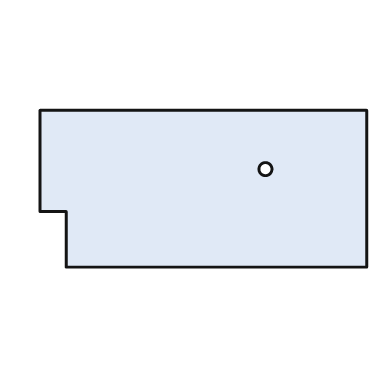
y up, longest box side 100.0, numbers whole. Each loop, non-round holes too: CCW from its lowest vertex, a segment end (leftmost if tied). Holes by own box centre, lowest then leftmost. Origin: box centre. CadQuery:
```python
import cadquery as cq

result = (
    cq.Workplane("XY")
    .moveTo(-42.0, -24.0)
    .lineTo(50.0, -24.0)
    .lineTo(50.0, 24.0)
    .lineTo(-50.0, 24.0)
    .lineTo(-50.0, -7.0)
    .lineTo(-42.0, -7.0)
    .close()
    .moveTo(19.0, 6.0)
    .circle(2.0)
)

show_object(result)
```